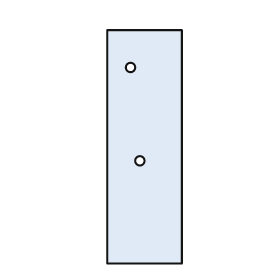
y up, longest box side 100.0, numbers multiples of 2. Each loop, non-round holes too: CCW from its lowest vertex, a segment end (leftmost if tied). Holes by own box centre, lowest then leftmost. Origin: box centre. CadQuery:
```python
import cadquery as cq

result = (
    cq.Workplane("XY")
    .moveTo(-16.0, -50.0)
    .lineTo(16.0, -50.0)
    .lineTo(16.0, 50.0)
    .lineTo(-16.0, 50.0)
    .close()
    .moveTo(-2.0, -6.0)
    .circle(2.0)
    .moveTo(-6.0, 34.0)
    .circle(2.0)
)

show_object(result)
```